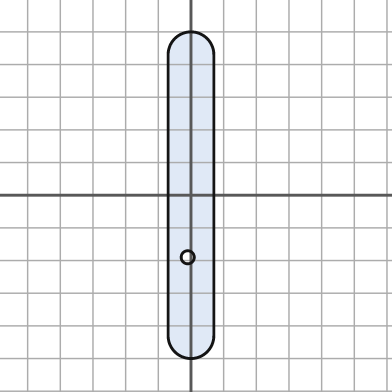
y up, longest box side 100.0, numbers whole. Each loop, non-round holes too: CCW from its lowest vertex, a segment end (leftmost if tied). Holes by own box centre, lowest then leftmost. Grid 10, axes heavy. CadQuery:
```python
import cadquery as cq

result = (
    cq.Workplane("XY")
    .moveTo(-7.0, -43.0)
    .threePointArc((0.0, -50.0), (7.0, -43.0))
    .lineTo(7.0, 43.0)
    .threePointArc((0.0, 50.0), (-7.0, 43.0))
    .close()
    .moveTo(-1.0, -19.0)
    .circle(2.0)
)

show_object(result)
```